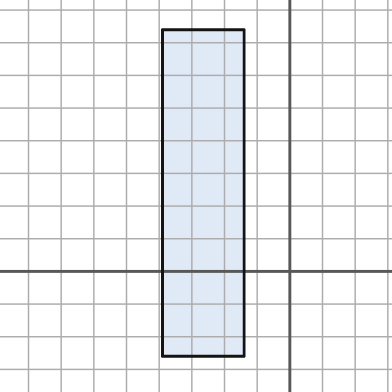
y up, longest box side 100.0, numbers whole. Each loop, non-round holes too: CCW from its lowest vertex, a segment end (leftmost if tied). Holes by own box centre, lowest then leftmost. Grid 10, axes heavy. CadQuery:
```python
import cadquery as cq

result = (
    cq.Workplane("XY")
    .moveTo(-39.0, -26.0)
    .lineTo(-14.0, -26.0)
    .lineTo(-14.0, 74.0)
    .lineTo(-39.0, 74.0)
    .close()
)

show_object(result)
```